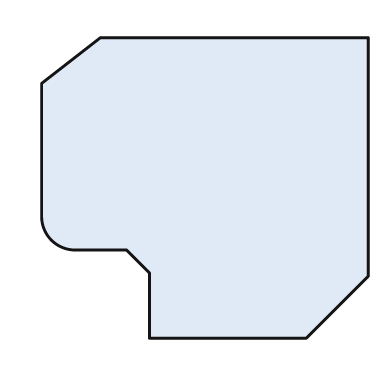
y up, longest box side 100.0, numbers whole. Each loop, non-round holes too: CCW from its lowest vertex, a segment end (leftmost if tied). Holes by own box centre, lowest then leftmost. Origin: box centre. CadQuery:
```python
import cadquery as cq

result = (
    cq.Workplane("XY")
    .moveTo(-17.0, -46.0)
    .lineTo(31.0, -46.0)
    .lineTo(50.0, -27.0)
    .lineTo(50.0, 46.0)
    .lineTo(-32.0, 46.0)
    .lineTo(-50.0, 32.0)
    .lineTo(-50.0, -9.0)
    .threePointArc((-47.0, -16.0), (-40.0, -19.0))
    .lineTo(-24.0, -19.0)
    .lineTo(-17.0, -26.0)
    .close()
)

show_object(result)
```